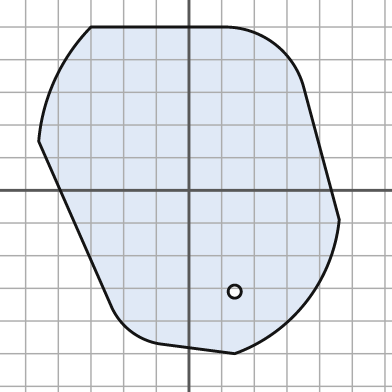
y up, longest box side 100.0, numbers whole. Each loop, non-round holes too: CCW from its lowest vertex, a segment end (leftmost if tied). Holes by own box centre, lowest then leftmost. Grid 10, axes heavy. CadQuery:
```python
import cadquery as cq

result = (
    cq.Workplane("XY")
    .moveTo(14.0, -50.0)
    .threePointArc((36.0, -34.0), (46.0, -9.0))
    .lineTo(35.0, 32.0)
    .threePointArc((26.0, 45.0), (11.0, 50.0))
    .lineTo(-30.0, 50.0)
    .threePointArc((-41.0, 34.0), (-46.0, 15.0))
    .lineTo(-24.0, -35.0)
    .threePointArc((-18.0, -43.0), (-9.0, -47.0))
    .close()
    .moveTo(14.0, -31.0)
    .circle(2.0)
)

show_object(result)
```